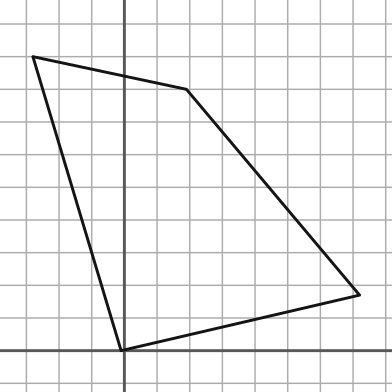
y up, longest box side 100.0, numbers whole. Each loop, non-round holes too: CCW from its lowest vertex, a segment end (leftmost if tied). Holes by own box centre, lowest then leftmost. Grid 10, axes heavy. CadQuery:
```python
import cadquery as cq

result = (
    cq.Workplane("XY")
    .moveTo(-1.0, 0.0)
    .lineTo(72.0, 17.0)
    .lineTo(19.0, 80.0)
    .lineTo(-28.0, 90.0)
    .close()
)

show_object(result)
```